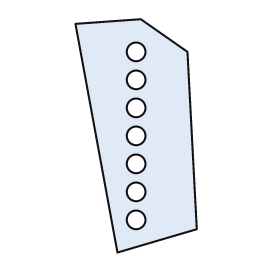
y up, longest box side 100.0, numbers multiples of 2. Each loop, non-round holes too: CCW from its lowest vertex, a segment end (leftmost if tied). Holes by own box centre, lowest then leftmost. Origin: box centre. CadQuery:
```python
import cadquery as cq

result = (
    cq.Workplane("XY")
    .moveTo(-8.0, -50.0)
    .lineTo(26.0, -40.0)
    .lineTo(22.0, 36.0)
    .lineTo(2.0, 50.0)
    .lineTo(-26.0, 48.0)
    .close()
    .moveTo(0.0, -36.0)
    .circle(4.0)
    .moveTo(0.0, -24.0)
    .circle(4.0)
    .moveTo(0.0, -12.0)
    .circle(4.0)
    .moveTo(0.0, 0.0)
    .circle(4.0)
    .moveTo(0.0, 12.0)
    .circle(4.0)
    .moveTo(0.0, 24.0)
    .circle(4.0)
    .moveTo(0.0, 36.0)
    .circle(4.0)
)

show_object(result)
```